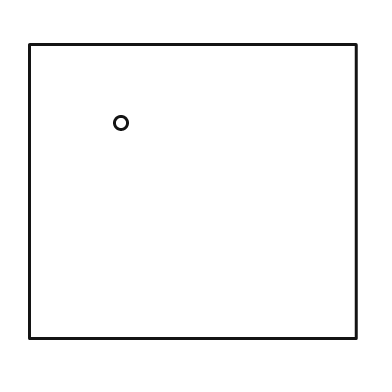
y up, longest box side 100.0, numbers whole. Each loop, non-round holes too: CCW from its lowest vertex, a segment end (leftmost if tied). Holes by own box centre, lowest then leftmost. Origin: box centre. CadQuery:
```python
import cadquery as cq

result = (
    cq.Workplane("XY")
    .moveTo(-50.0, -45.0)
    .lineTo(50.0, -45.0)
    .lineTo(50.0, 45.0)
    .lineTo(-50.0, 45.0)
    .close()
    .moveTo(-22.0, 21.0)
    .circle(2.0)
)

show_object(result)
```